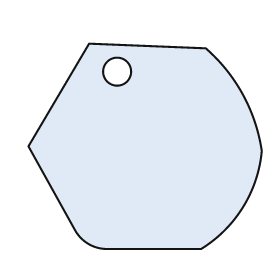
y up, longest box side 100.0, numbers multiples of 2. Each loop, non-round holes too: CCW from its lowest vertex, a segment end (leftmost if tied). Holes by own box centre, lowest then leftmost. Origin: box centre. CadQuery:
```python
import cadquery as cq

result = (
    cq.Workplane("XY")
    .moveTo(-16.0, -44.0)
    .lineTo(24.0, -44.0)
    .threePointArc((42.0, -26.0), (50.0, -2.0))
    .threePointArc((42.0, 22.0), (26.0, 42.0))
    .lineTo(-24.0, 44.0)
    .lineTo(-50.0, 0.0)
    .lineTo(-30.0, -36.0)
    .threePointArc((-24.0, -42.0), (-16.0, -44.0))
    .close()
    .moveTo(-12.0, 32.0)
    .circle(6.0)
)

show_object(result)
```